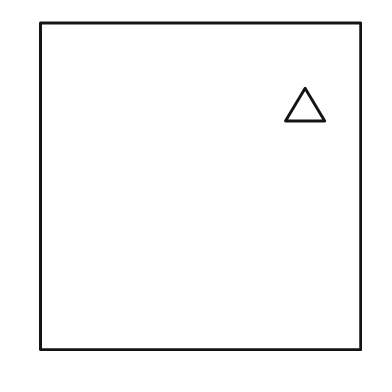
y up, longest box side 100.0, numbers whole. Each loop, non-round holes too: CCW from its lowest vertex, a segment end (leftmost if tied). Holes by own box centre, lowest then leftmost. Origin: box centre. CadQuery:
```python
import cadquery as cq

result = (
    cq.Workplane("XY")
    .moveTo(-49.0, -50.0)
    .lineTo(49.0, -50.0)
    .lineTo(49.0, 50.0)
    .lineTo(-49.0, 50.0)
    .close()
    .moveTo(26.0, 20.0)
    .lineTo(38.0, 20.0)
    .lineTo(32.0, 30.0)
    .close()
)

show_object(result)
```